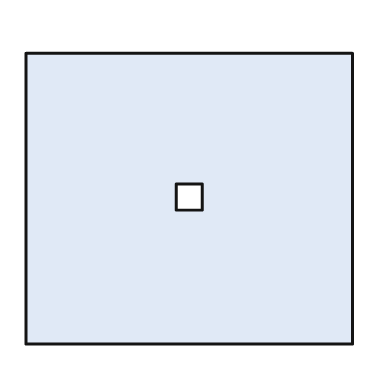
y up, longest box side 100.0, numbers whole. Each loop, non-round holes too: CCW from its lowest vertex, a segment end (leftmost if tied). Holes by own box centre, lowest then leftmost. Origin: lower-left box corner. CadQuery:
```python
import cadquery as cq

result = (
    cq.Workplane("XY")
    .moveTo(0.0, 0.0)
    .lineTo(100.0, 0.0)
    .lineTo(100.0, 89.0)
    .lineTo(0.0, 89.0)
    .close()
    .moveTo(46.0, 41.0)
    .lineTo(54.0, 41.0)
    .lineTo(54.0, 49.0)
    .lineTo(46.0, 49.0)
    .close()
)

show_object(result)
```